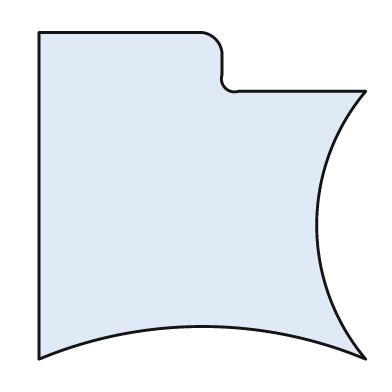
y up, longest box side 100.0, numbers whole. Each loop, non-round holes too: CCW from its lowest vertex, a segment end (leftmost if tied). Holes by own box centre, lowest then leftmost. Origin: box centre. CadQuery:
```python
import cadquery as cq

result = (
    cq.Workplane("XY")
    .moveTo(-50.0, -50.0)
    .threePointArc((0.0, -40.0), (50.0, -50.0))
    .threePointArc((35.0, -9.0), (50.0, 32.0))
    .lineTo(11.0, 32.0)
    .threePointArc((7.0, 33.0), (6.0, 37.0))
    .lineTo(6.0, 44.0)
    .threePointArc((4.0, 48.0), (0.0, 50.0))
    .lineTo(-50.0, 50.0)
    .close()
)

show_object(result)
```